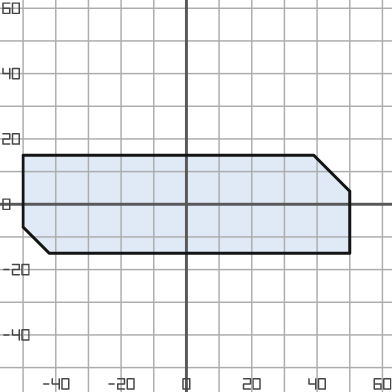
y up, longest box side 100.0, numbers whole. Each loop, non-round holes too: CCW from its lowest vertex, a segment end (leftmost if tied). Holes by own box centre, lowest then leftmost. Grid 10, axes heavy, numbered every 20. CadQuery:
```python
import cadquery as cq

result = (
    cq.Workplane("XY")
    .moveTo(-42.0, -15.0)
    .lineTo(50.0, -15.0)
    .lineTo(50.0, 4.0)
    .lineTo(39.0, 15.0)
    .lineTo(-50.0, 15.0)
    .lineTo(-50.0, -7.0)
    .close()
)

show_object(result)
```